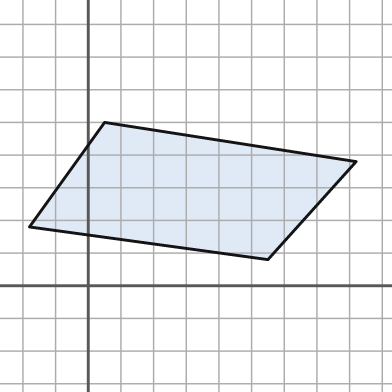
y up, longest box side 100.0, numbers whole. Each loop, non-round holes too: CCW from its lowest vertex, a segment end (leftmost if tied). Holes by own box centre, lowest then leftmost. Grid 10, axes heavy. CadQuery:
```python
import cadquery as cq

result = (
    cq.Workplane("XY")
    .moveTo(55.0, 8.0)
    .lineTo(82.0, 38.0)
    .lineTo(5.0, 50.0)
    .lineTo(-18.0, 18.0)
    .close()
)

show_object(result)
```